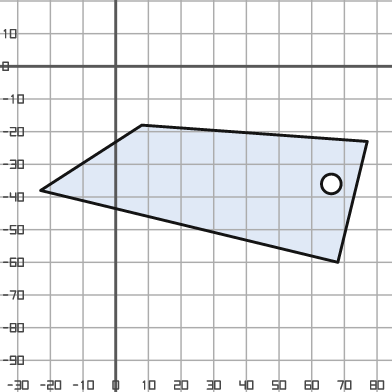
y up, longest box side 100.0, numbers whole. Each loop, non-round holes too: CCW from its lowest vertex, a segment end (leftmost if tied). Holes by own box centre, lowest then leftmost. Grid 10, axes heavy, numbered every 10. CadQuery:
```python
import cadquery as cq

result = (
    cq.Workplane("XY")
    .moveTo(68.0, -60.0)
    .lineTo(77.0, -23.0)
    .lineTo(8.0, -18.0)
    .lineTo(-23.0, -38.0)
    .close()
    .moveTo(66.0, -36.0)
    .circle(3.0)
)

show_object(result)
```